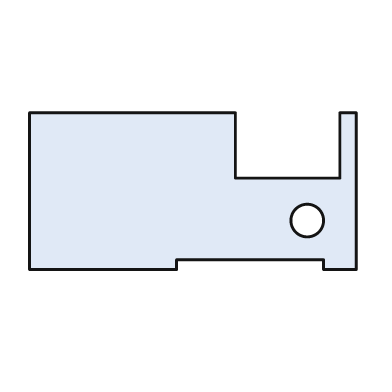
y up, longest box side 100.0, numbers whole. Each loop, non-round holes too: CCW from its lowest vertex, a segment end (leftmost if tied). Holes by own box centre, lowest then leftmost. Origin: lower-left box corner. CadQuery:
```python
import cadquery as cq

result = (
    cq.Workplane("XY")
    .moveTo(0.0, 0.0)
    .lineTo(45.0, 0.0)
    .lineTo(45.0, 3.0)
    .lineTo(90.0, 3.0)
    .lineTo(90.0, 0.0)
    .lineTo(100.0, 0.0)
    .lineTo(100.0, 48.0)
    .lineTo(95.0, 48.0)
    .lineTo(95.0, 28.0)
    .lineTo(63.0, 28.0)
    .lineTo(63.0, 48.0)
    .lineTo(0.0, 48.0)
    .close()
    .moveTo(85.0, 15.0)
    .circle(5.0)
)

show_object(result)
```